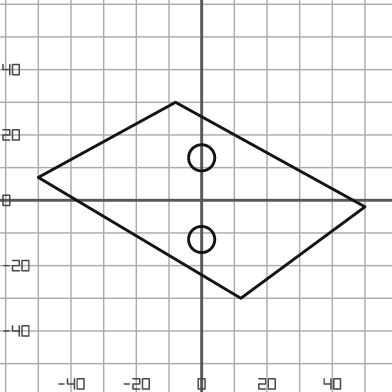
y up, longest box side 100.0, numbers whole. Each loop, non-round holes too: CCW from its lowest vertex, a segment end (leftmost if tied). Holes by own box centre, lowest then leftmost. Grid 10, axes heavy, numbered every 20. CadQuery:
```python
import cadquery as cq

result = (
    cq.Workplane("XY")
    .moveTo(12.0, -30.0)
    .lineTo(50.0, -2.0)
    .lineTo(-8.0, 30.0)
    .lineTo(-50.0, 7.0)
    .close()
    .moveTo(0.0, -12.0)
    .circle(4.0)
    .moveTo(0.0, 13.0)
    .circle(4.0)
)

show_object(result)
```